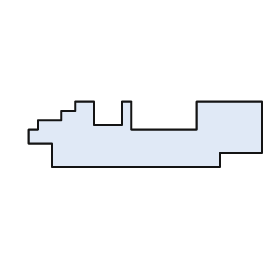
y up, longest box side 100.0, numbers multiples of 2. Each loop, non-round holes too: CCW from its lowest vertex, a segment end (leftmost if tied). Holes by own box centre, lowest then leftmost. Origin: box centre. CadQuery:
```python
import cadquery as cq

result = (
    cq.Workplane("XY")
    .moveTo(-40.0, -14.0)
    .lineTo(32.0, -14.0)
    .lineTo(32.0, -8.0)
    .lineTo(50.0, -8.0)
    .lineTo(50.0, 14.0)
    .lineTo(22.0, 14.0)
    .lineTo(22.0, 2.0)
    .lineTo(-6.0, 2.0)
    .lineTo(-6.0, 14.0)
    .lineTo(-10.0, 14.0)
    .lineTo(-10.0, 4.0)
    .lineTo(-22.0, 4.0)
    .lineTo(-22.0, 14.0)
    .lineTo(-30.0, 14.0)
    .lineTo(-30.0, 10.0)
    .lineTo(-36.0, 10.0)
    .lineTo(-36.0, 6.0)
    .lineTo(-46.0, 6.0)
    .lineTo(-46.0, 2.0)
    .lineTo(-50.0, 2.0)
    .lineTo(-50.0, -4.0)
    .lineTo(-40.0, -4.0)
    .close()
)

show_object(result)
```